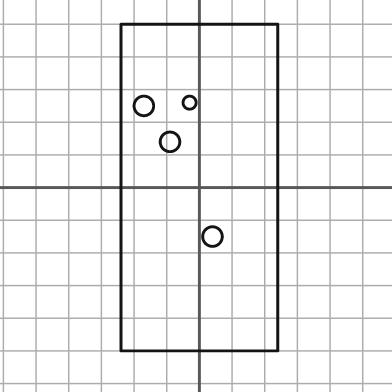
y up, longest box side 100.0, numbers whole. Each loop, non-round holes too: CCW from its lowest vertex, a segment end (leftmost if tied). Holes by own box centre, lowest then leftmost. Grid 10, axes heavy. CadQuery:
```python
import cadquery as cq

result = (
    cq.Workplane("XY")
    .moveTo(-24.0, -50.0)
    .lineTo(24.0, -50.0)
    .lineTo(24.0, 50.0)
    .lineTo(-24.0, 50.0)
    .close()
    .moveTo(4.0, -15.0)
    .circle(3.0)
    .moveTo(-9.0, 14.0)
    .circle(3.0)
    .moveTo(-17.0, 25.0)
    .circle(3.0)
    .moveTo(-3.0, 26.0)
    .circle(2.0)
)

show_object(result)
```